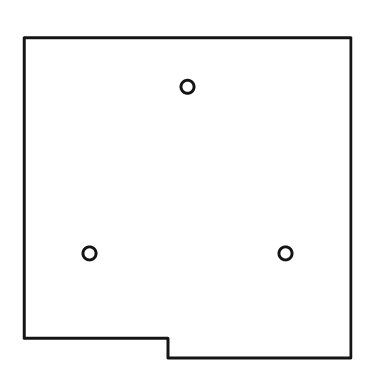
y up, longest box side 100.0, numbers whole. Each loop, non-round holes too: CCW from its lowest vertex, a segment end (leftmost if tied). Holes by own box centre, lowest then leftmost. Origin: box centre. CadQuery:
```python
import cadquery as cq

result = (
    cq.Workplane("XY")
    .moveTo(-6.0, -49.0)
    .lineTo(50.0, -49.0)
    .lineTo(50.0, 49.0)
    .lineTo(-50.0, 49.0)
    .lineTo(-50.0, -43.0)
    .lineTo(-6.0, -43.0)
    .close()
    .moveTo(-30.0, -17.0)
    .circle(2.0)
    .moveTo(30.0, -17.0)
    .circle(2.0)
    .moveTo(0.0, 34.0)
    .circle(2.0)
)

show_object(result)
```